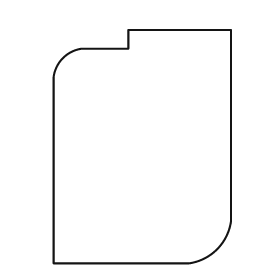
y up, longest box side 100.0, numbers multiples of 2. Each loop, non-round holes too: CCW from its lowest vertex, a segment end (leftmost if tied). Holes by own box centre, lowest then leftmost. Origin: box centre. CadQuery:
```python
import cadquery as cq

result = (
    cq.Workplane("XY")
    .moveTo(-38.0, -50.0)
    .lineTo(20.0, -50.0)
    .threePointArc((32.0, -44.0), (38.0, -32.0))
    .lineTo(38.0, 50.0)
    .lineTo(-6.0, 50.0)
    .lineTo(-6.0, 42.0)
    .lineTo(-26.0, 42.0)
    .threePointArc((-34.0, 38.0), (-38.0, 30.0))
    .close()
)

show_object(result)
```